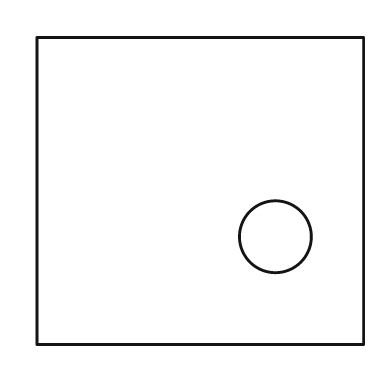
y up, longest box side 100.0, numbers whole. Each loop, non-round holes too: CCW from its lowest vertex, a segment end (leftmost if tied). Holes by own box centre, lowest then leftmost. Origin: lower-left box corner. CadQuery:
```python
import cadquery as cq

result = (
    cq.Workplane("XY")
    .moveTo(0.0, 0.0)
    .lineTo(100.0, 0.0)
    .lineTo(100.0, 94.0)
    .lineTo(0.0, 94.0)
    .close()
    .moveTo(73.0, 33.0)
    .circle(11.0)
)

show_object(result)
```